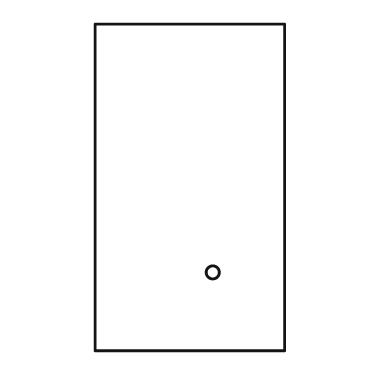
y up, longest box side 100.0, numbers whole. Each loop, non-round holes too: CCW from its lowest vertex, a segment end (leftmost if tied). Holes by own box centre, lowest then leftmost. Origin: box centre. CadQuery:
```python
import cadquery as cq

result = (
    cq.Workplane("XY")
    .moveTo(-29.0, -50.0)
    .lineTo(29.0, -50.0)
    .lineTo(29.0, 50.0)
    .lineTo(-29.0, 50.0)
    .close()
    .moveTo(7.0, -26.0)
    .circle(2.0)
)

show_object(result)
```